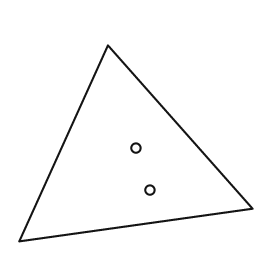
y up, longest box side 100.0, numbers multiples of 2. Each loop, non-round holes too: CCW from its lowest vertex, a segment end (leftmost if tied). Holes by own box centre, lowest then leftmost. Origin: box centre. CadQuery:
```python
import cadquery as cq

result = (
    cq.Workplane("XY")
    .moveTo(-50.0, -42.0)
    .lineTo(50.0, -28.0)
    .lineTo(-12.0, 42.0)
    .close()
    .moveTo(6.0, -20.0)
    .circle(2.0)
    .moveTo(0.0, -2.0)
    .circle(2.0)
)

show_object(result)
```